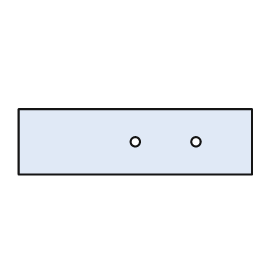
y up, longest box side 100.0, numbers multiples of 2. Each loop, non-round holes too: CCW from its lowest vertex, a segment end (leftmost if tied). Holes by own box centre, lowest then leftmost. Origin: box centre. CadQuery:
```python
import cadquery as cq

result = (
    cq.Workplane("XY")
    .moveTo(-50.0, -14.0)
    .lineTo(50.0, -14.0)
    .lineTo(50.0, 14.0)
    .lineTo(-50.0, 14.0)
    .close()
    .moveTo(0.0, 0.0)
    .circle(2.0)
    .moveTo(26.0, 0.0)
    .circle(2.0)
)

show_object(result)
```